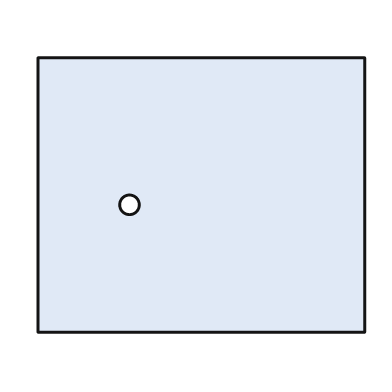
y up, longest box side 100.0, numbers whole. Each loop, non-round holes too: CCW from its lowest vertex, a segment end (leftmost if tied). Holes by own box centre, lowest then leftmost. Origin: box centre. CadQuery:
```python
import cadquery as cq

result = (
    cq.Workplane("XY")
    .moveTo(-50.0, -42.0)
    .lineTo(50.0, -42.0)
    .lineTo(50.0, 42.0)
    .lineTo(-50.0, 42.0)
    .close()
    .moveTo(-22.0, -3.0)
    .circle(3.0)
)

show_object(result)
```